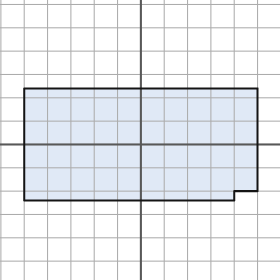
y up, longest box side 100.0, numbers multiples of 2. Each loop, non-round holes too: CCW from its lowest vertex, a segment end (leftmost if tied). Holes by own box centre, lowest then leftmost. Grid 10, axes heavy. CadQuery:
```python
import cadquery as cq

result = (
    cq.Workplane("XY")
    .moveTo(-50.0, -24.0)
    .lineTo(40.0, -24.0)
    .lineTo(40.0, -20.0)
    .lineTo(50.0, -20.0)
    .lineTo(50.0, 24.0)
    .lineTo(-50.0, 24.0)
    .close()
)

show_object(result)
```